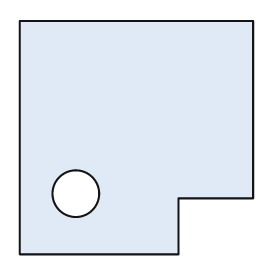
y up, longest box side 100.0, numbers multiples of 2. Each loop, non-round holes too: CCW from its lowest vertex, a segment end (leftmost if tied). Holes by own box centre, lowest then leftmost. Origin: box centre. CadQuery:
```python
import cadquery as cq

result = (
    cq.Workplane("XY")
    .moveTo(-50.0, -50.0)
    .lineTo(18.0, -50.0)
    .lineTo(18.0, -26.0)
    .lineTo(50.0, -26.0)
    .lineTo(50.0, 50.0)
    .lineTo(-50.0, 50.0)
    .close()
    .moveTo(-26.0, -24.0)
    .circle(10.0)
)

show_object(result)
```